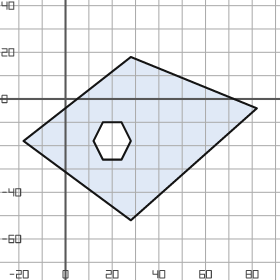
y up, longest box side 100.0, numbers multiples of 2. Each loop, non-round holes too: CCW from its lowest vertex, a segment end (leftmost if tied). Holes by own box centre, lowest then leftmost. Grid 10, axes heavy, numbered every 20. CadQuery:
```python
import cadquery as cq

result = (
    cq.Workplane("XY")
    .moveTo(28.0, -52.0)
    .lineTo(82.0, -4.0)
    .lineTo(28.0, 18.0)
    .lineTo(-18.0, -18.0)
    .close()
    .moveTo(16.0, -26.0)
    .lineTo(24.0, -26.0)
    .lineTo(28.0, -18.0)
    .lineTo(24.0, -10.0)
    .lineTo(16.0, -10.0)
    .lineTo(12.0, -18.0)
    .close()
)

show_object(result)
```